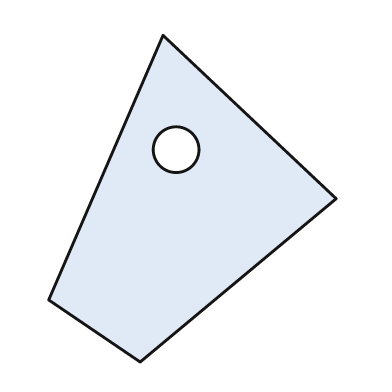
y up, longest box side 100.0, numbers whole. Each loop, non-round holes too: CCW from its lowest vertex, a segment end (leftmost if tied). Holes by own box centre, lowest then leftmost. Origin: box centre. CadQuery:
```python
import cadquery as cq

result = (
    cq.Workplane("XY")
    .moveTo(-16.0, -50.0)
    .lineTo(44.0, 0.0)
    .lineTo(-9.0, 50.0)
    .lineTo(-44.0, -31.0)
    .close()
    .moveTo(-5.0, 15.0)
    .circle(7.0)
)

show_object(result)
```